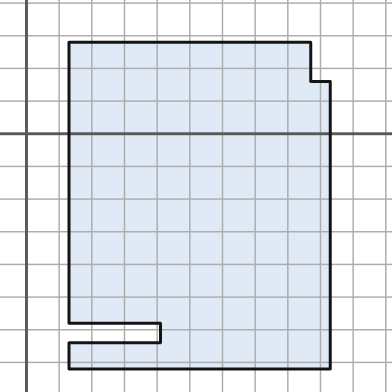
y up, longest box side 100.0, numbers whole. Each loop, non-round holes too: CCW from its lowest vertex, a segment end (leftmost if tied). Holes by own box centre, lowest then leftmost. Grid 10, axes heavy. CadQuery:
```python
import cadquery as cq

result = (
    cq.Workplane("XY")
    .moveTo(13.0, -72.0)
    .lineTo(93.0, -72.0)
    .lineTo(93.0, 16.0)
    .lineTo(87.0, 16.0)
    .lineTo(87.0, 28.0)
    .lineTo(13.0, 28.0)
    .lineTo(13.0, -58.0)
    .lineTo(41.0, -58.0)
    .lineTo(41.0, -64.0)
    .lineTo(13.0, -64.0)
    .close()
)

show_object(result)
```